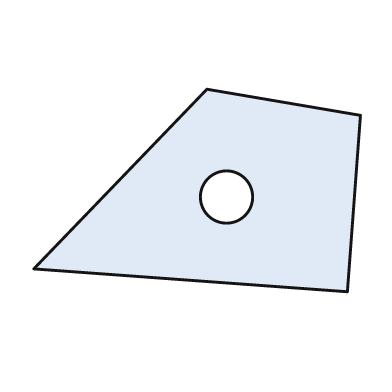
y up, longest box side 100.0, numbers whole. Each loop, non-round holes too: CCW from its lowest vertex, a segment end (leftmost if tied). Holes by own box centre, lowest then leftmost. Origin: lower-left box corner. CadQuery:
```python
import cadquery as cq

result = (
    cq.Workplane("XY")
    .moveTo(96.0, 0.0)
    .lineTo(100.0, 54.0)
    .lineTo(53.0, 62.0)
    .lineTo(0.0, 7.0)
    .close()
    .moveTo(59.0, 29.0)
    .circle(8.0)
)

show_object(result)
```